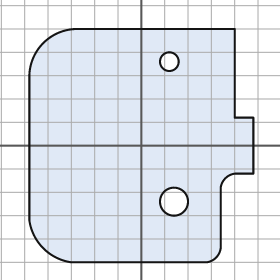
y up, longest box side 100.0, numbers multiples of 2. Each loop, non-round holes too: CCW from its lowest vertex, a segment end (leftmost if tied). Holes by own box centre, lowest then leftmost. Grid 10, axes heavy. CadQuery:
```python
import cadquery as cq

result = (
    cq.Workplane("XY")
    .moveTo(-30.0, -50.0)
    .lineTo(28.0, -50.0)
    .threePointArc((32.0, -48.0), (34.0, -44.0))
    .lineTo(34.0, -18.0)
    .threePointArc((36.0, -14.0), (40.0, -12.0))
    .lineTo(48.0, -12.0)
    .lineTo(48.0, 12.0)
    .lineTo(40.0, 12.0)
    .lineTo(40.0, 50.0)
    .lineTo(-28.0, 50.0)
    .threePointArc((-42.0, 44.0), (-48.0, 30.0))
    .lineTo(-48.0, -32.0)
    .threePointArc((-42.0, -44.0), (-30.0, -50.0))
    .close()
    .moveTo(14.0, -24.0)
    .circle(6.0)
    .moveTo(12.0, 36.0)
    .circle(4.0)
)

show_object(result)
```